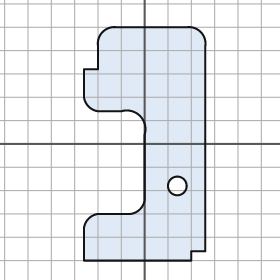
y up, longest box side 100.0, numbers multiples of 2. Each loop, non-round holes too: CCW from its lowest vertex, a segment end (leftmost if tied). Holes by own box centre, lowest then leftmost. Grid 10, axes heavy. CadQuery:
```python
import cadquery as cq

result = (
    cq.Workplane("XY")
    .moveTo(-26.0, -50.0)
    .lineTo(20.0, -50.0)
    .lineTo(20.0, -46.0)
    .lineTo(26.0, -46.0)
    .lineTo(26.0, 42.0)
    .threePointArc((24.0, 48.0), (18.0, 50.0))
    .lineTo(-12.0, 50.0)
    .threePointArc((-18.0, 48.0), (-20.0, 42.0))
    .lineTo(-20.0, 32.0)
    .lineTo(-26.0, 32.0)
    .lineTo(-26.0, 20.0)
    .threePointArc((-24.0, 16.0), (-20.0, 14.0))
    .lineTo(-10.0, 14.0)
    .threePointArc((-2.0, 12.0), (0.0, 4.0))
    .lineTo(0.0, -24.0)
    .threePointArc((-2.0, -28.0), (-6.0, -30.0))
    .lineTo(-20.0, -30.0)
    .threePointArc((-24.0, -32.0), (-26.0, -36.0))
    .close()
    .moveTo(14.0, -18.0)
    .circle(4.0)
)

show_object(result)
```